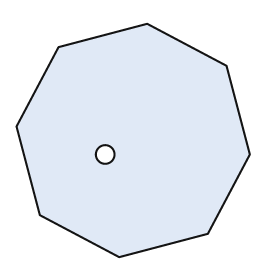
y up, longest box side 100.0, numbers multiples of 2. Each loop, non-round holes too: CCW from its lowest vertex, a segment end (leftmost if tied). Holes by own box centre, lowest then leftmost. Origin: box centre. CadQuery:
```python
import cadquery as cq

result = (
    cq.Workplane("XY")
    .moveTo(-6.0, -50.0)
    .lineTo(32.0, -40.0)
    .lineTo(50.0, -6.0)
    .lineTo(40.0, 32.0)
    .lineTo(6.0, 50.0)
    .lineTo(-32.0, 40.0)
    .lineTo(-50.0, 6.0)
    .lineTo(-40.0, -32.0)
    .close()
    .moveTo(-12.0, -6.0)
    .circle(4.0)
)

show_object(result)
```